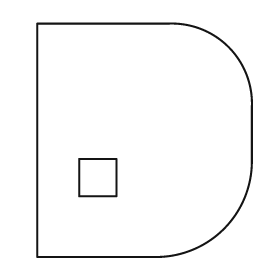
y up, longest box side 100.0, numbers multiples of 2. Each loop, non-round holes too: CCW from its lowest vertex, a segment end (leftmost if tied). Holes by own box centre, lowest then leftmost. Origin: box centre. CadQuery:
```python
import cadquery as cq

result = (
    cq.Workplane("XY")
    .moveTo(-46.0, -50.0)
    .lineTo(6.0, -50.0)
    .threePointArc((34.0, -38.0), (46.0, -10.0))
    .lineTo(46.0, 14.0)
    .threePointArc((36.0, 40.0), (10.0, 50.0))
    .lineTo(-46.0, 50.0)
    .close()
    .moveTo(-28.0, -24.0)
    .lineTo(-12.0, -24.0)
    .lineTo(-12.0, -8.0)
    .lineTo(-28.0, -8.0)
    .close()
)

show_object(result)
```